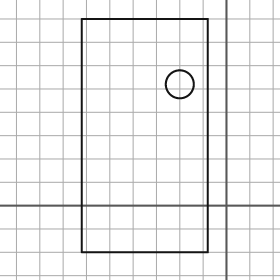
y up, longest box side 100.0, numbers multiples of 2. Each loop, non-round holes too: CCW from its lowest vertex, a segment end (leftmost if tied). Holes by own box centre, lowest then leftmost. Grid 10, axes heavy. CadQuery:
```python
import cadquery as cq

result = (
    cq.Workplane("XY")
    .moveTo(-62.0, -20.0)
    .lineTo(-8.0, -20.0)
    .lineTo(-8.0, 80.0)
    .lineTo(-62.0, 80.0)
    .close()
    .moveTo(-20.0, 52.0)
    .circle(6.0)
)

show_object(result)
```